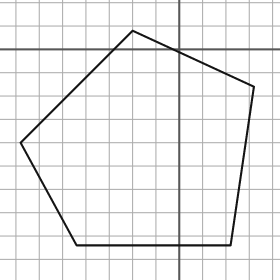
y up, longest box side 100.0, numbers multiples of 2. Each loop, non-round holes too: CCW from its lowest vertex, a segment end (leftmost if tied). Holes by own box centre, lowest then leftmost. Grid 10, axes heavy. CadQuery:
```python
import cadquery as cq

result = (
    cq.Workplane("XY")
    .moveTo(-44.0, -84.0)
    .lineTo(22.0, -84.0)
    .lineTo(32.0, -16.0)
    .lineTo(-20.0, 8.0)
    .lineTo(-68.0, -40.0)
    .close()
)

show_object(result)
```